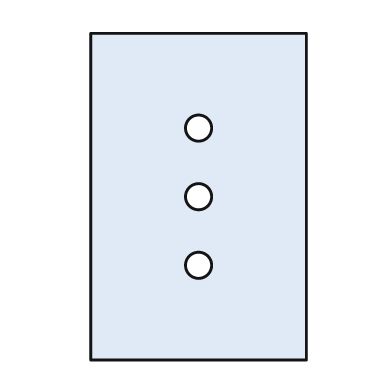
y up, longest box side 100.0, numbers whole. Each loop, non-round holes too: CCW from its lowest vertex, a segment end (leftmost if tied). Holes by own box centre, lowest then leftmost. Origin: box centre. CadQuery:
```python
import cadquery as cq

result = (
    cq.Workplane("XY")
    .moveTo(-33.0, -50.0)
    .lineTo(33.0, -50.0)
    .lineTo(33.0, 50.0)
    .lineTo(-33.0, 50.0)
    .close()
    .moveTo(0.0, -21.0)
    .circle(4.0)
    .moveTo(0.0, 0.0)
    .circle(4.0)
    .moveTo(0.0, 21.0)
    .circle(4.0)
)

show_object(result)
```